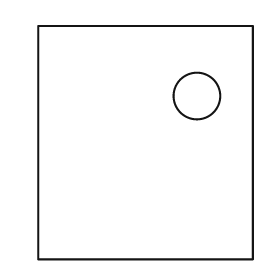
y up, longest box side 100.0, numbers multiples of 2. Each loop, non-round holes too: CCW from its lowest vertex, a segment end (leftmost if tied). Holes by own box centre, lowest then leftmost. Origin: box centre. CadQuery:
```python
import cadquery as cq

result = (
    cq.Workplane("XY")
    .moveTo(-46.0, -50.0)
    .lineTo(46.0, -50.0)
    .lineTo(46.0, 50.0)
    .lineTo(-46.0, 50.0)
    .close()
    .moveTo(22.0, 20.0)
    .circle(10.0)
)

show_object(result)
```